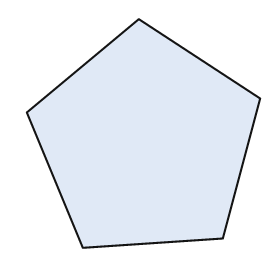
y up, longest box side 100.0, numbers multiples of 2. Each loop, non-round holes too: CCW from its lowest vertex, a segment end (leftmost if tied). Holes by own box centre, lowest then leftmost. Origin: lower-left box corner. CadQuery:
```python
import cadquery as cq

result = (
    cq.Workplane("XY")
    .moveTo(24.0, 0.0)
    .lineTo(84.0, 4.0)
    .lineTo(100.0, 64.0)
    .lineTo(48.0, 98.0)
    .lineTo(0.0, 58.0)
    .close()
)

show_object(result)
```